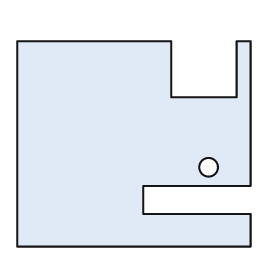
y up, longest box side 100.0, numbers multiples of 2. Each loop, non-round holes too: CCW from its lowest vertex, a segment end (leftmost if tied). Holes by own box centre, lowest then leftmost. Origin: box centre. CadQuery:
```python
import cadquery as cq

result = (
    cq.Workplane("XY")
    .moveTo(-50.0, -44.0)
    .lineTo(50.0, -44.0)
    .lineTo(50.0, -30.0)
    .lineTo(4.0, -30.0)
    .lineTo(4.0, -18.0)
    .lineTo(50.0, -18.0)
    .lineTo(50.0, 44.0)
    .lineTo(44.0, 44.0)
    .lineTo(44.0, 20.0)
    .lineTo(16.0, 20.0)
    .lineTo(16.0, 44.0)
    .lineTo(-50.0, 44.0)
    .close()
    .moveTo(32.0, -10.0)
    .circle(4.0)
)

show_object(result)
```